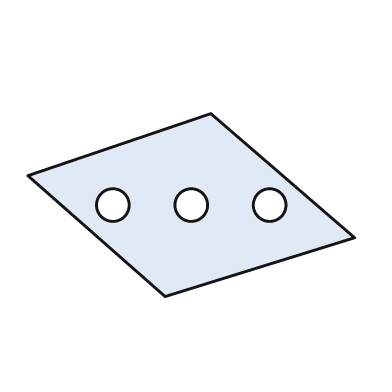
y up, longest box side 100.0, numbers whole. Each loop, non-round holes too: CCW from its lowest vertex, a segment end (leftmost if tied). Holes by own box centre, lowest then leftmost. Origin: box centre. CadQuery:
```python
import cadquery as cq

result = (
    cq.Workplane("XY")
    .moveTo(-8.0, -28.0)
    .lineTo(50.0, -10.0)
    .lineTo(6.0, 28.0)
    .lineTo(-50.0, 9.0)
    .close()
    .moveTo(-24.0, 0.0)
    .circle(5.0)
    .moveTo(0.0, 0.0)
    .circle(5.0)
    .moveTo(24.0, 0.0)
    .circle(5.0)
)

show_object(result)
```